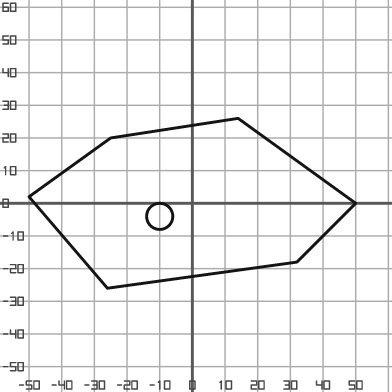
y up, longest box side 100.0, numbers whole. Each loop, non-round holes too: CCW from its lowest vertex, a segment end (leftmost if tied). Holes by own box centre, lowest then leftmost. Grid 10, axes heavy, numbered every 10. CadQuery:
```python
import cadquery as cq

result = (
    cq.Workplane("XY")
    .moveTo(-26.0, -26.0)
    .lineTo(32.0, -18.0)
    .lineTo(50.0, 0.0)
    .lineTo(14.0, 26.0)
    .lineTo(-25.0, 20.0)
    .lineTo(-50.0, 2.0)
    .close()
    .moveTo(-10.0, -4.0)
    .circle(4.0)
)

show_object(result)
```